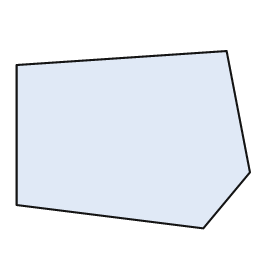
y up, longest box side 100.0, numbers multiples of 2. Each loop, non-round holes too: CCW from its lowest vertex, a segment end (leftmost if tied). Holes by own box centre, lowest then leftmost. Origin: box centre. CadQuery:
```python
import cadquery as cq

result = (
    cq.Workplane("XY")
    .moveTo(30.0, -38.0)
    .lineTo(50.0, -14.0)
    .lineTo(40.0, 38.0)
    .lineTo(-50.0, 32.0)
    .lineTo(-50.0, -28.0)
    .close()
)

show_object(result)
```